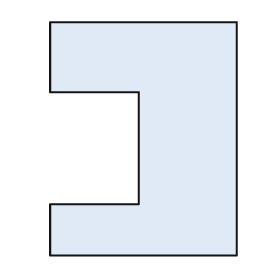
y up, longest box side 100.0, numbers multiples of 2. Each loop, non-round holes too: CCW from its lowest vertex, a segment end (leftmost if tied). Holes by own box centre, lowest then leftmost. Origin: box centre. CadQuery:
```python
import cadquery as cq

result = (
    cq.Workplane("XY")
    .moveTo(-40.0, -50.0)
    .lineTo(40.0, -50.0)
    .lineTo(40.0, 50.0)
    .lineTo(-40.0, 50.0)
    .lineTo(-40.0, 20.0)
    .lineTo(-2.0, 20.0)
    .lineTo(-2.0, -28.0)
    .lineTo(-40.0, -28.0)
    .close()
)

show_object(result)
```